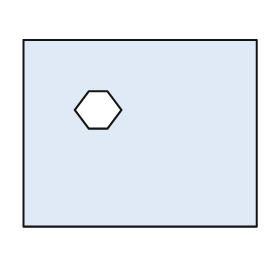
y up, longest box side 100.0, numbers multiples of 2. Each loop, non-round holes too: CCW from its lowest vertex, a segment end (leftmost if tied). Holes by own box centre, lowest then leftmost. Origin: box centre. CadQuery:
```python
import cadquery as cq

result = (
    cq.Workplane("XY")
    .moveTo(-50.0, -40.0)
    .lineTo(50.0, -40.0)
    .lineTo(50.0, 40.0)
    .lineTo(-50.0, 40.0)
    .close()
    .moveTo(-22.0, 2.0)
    .lineTo(-14.0, 2.0)
    .lineTo(-8.0, 10.0)
    .lineTo(-14.0, 18.0)
    .lineTo(-22.0, 18.0)
    .lineTo(-28.0, 10.0)
    .close()
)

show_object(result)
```